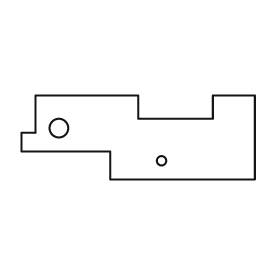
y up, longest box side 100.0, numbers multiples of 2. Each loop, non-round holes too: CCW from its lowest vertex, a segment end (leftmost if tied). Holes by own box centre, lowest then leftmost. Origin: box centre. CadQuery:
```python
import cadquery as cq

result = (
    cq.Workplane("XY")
    .moveTo(-12.0, -18.0)
    .lineTo(50.0, -18.0)
    .lineTo(50.0, 18.0)
    .lineTo(32.0, 18.0)
    .lineTo(32.0, 8.0)
    .lineTo(0.0, 8.0)
    .lineTo(0.0, 18.0)
    .lineTo(-44.0, 18.0)
    .lineTo(-44.0, 2.0)
    .lineTo(-50.0, 2.0)
    .lineTo(-50.0, -6.0)
    .lineTo(-12.0, -6.0)
    .close()
    .moveTo(10.0, -10.0)
    .circle(2.0)
    .moveTo(-34.0, 4.0)
    .circle(4.0)
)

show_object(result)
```